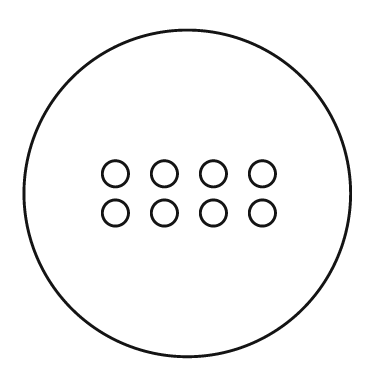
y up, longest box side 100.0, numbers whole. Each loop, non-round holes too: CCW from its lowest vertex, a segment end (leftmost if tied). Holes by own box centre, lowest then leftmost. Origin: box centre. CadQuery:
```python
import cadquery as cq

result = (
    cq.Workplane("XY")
    .moveTo(0.0, 0.0)
    .circle(50.0)
    .moveTo(-22.0, -6.0)
    .circle(4.0)
    .moveTo(-7.0, -6.0)
    .circle(4.0)
    .moveTo(8.0, -6.0)
    .circle(4.0)
    .moveTo(23.0, -6.0)
    .circle(4.0)
    .moveTo(-22.0, 6.0)
    .circle(4.0)
    .moveTo(-7.0, 6.0)
    .circle(4.0)
    .moveTo(8.0, 6.0)
    .circle(4.0)
    .moveTo(23.0, 6.0)
    .circle(4.0)
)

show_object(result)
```